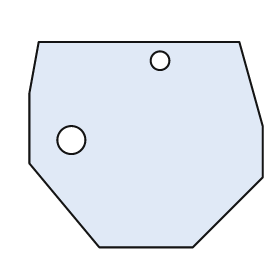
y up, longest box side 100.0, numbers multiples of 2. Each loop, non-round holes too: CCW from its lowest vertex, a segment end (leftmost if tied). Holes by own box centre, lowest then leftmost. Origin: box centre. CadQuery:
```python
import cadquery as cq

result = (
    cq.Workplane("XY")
    .moveTo(-20.0, -44.0)
    .lineTo(20.0, -44.0)
    .lineTo(50.0, -14.0)
    .lineTo(50.0, 8.0)
    .lineTo(40.0, 44.0)
    .lineTo(-46.0, 44.0)
    .lineTo(-50.0, 22.0)
    .lineTo(-50.0, -8.0)
    .close()
    .moveTo(-32.0, 2.0)
    .circle(6.0)
    .moveTo(6.0, 36.0)
    .circle(4.0)
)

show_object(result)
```